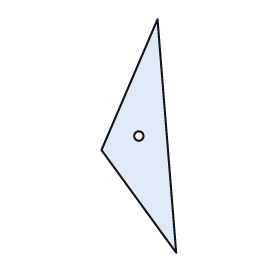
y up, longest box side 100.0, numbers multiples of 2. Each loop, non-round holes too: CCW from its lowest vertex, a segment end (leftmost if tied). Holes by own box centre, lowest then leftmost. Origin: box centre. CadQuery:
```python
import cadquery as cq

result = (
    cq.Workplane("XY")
    .moveTo(16.0, -50.0)
    .lineTo(8.0, 50.0)
    .lineTo(-16.0, -6.0)
    .close()
    .moveTo(0.0, 0.0)
    .circle(2.0)
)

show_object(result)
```